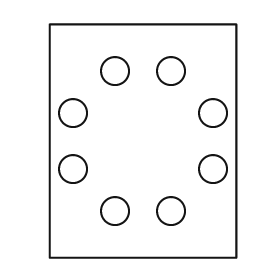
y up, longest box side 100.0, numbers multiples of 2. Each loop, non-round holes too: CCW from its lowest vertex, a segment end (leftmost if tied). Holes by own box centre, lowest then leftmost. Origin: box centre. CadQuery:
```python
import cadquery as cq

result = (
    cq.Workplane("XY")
    .moveTo(-40.0, -50.0)
    .lineTo(40.0, -50.0)
    .lineTo(40.0, 50.0)
    .lineTo(-40.0, 50.0)
    .close()
    .moveTo(-12.0, -30.0)
    .circle(6.0)
    .moveTo(12.0, -30.0)
    .circle(6.0)
    .moveTo(-30.0, -12.0)
    .circle(6.0)
    .moveTo(30.0, -12.0)
    .circle(6.0)
    .moveTo(-30.0, 12.0)
    .circle(6.0)
    .moveTo(30.0, 12.0)
    .circle(6.0)
    .moveTo(-12.0, 30.0)
    .circle(6.0)
    .moveTo(12.0, 30.0)
    .circle(6.0)
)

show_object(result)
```